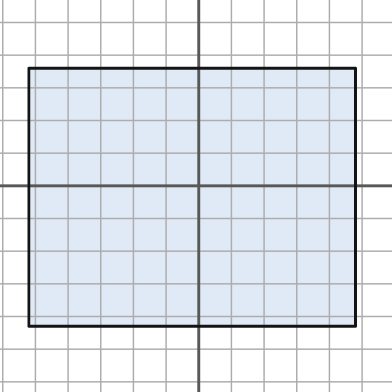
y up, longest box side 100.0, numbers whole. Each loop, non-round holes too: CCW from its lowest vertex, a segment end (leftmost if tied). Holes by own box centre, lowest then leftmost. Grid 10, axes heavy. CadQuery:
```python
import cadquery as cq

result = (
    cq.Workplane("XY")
    .moveTo(-52.0, -43.0)
    .lineTo(48.0, -43.0)
    .lineTo(48.0, 36.0)
    .lineTo(-52.0, 36.0)
    .close()
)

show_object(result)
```